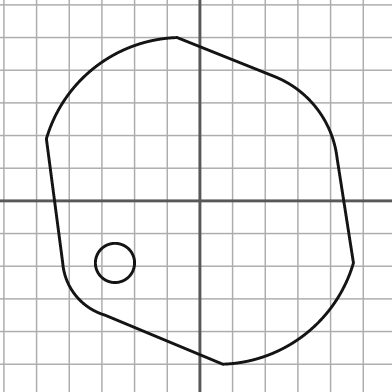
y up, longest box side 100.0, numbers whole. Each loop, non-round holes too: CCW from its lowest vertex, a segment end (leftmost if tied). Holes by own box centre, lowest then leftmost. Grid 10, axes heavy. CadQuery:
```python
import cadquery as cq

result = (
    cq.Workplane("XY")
    .moveTo(7.0, -50.0)
    .threePointArc((32.0, -41.0), (47.0, -19.0))
    .lineTo(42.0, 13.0)
    .threePointArc((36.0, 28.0), (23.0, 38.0))
    .lineTo(-7.0, 50.0)
    .threePointArc((-32.0, 41.0), (-47.0, 19.0))
    .lineTo(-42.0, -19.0)
    .threePointArc((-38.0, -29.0), (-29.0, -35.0))
    .close()
    .moveTo(-26.0, -19.0)
    .circle(6.0)
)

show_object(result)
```